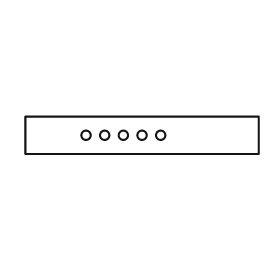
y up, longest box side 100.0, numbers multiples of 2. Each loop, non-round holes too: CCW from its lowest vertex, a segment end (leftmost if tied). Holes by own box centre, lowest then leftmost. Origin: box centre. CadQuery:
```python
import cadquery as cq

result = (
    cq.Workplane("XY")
    .moveTo(-50.0, -8.0)
    .lineTo(50.0, -8.0)
    .lineTo(50.0, 8.0)
    .lineTo(-50.0, 8.0)
    .close()
    .moveTo(-24.0, 0.0)
    .circle(2.0)
    .moveTo(-16.0, 0.0)
    .circle(2.0)
    .moveTo(-8.0, 0.0)
    .circle(2.0)
    .moveTo(0.0, 0.0)
    .circle(2.0)
    .moveTo(8.0, 0.0)
    .circle(2.0)
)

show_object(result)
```